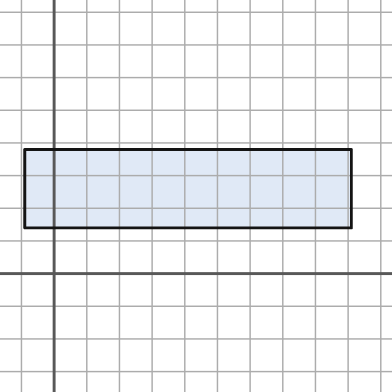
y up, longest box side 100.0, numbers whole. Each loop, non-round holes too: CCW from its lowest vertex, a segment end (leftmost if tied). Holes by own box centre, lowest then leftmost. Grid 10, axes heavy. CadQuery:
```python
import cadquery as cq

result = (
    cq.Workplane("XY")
    .moveTo(-9.0, 14.0)
    .lineTo(91.0, 14.0)
    .lineTo(91.0, 38.0)
    .lineTo(-9.0, 38.0)
    .close()
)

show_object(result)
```